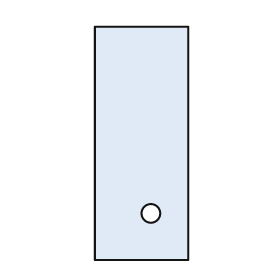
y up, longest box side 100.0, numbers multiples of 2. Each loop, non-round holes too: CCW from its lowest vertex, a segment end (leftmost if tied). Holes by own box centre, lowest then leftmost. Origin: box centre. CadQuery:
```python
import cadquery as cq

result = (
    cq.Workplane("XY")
    .moveTo(-20.0, -50.0)
    .lineTo(20.0, -50.0)
    .lineTo(20.0, 50.0)
    .lineTo(-20.0, 50.0)
    .close()
    .moveTo(4.0, -30.0)
    .circle(4.0)
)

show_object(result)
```